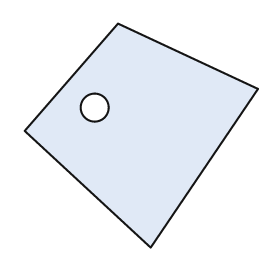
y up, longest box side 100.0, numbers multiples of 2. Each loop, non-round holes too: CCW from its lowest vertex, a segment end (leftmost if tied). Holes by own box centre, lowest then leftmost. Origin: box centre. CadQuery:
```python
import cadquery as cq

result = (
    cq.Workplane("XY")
    .moveTo(4.0, -48.0)
    .lineTo(50.0, 20.0)
    .lineTo(-10.0, 48.0)
    .lineTo(-50.0, 2.0)
    .close()
    .moveTo(-20.0, 12.0)
    .circle(6.0)
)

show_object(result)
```